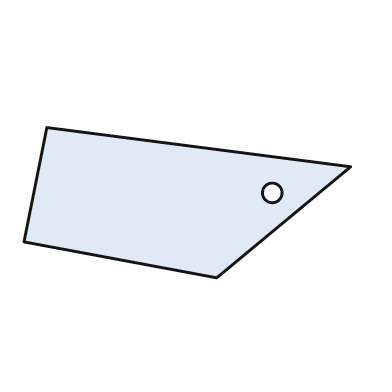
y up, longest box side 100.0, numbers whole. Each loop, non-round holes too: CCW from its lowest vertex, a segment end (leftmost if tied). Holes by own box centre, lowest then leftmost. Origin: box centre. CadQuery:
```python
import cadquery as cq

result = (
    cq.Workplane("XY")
    .moveTo(9.0, -23.0)
    .lineTo(50.0, 11.0)
    .lineTo(-43.0, 23.0)
    .lineTo(-50.0, -12.0)
    .close()
    .moveTo(26.0, 3.0)
    .circle(3.0)
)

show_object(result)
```